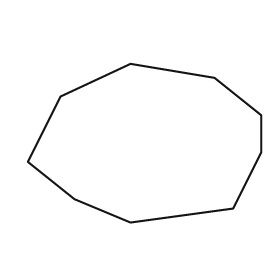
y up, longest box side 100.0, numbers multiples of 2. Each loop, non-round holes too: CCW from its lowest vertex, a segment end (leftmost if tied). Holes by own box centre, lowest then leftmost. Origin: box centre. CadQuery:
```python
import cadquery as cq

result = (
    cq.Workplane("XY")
    .moveTo(-6.0, -34.0)
    .lineTo(38.0, -28.0)
    .lineTo(50.0, -4.0)
    .lineTo(50.0, 12.0)
    .lineTo(30.0, 28.0)
    .lineTo(-6.0, 34.0)
    .lineTo(-36.0, 20.0)
    .lineTo(-50.0, -8.0)
    .lineTo(-30.0, -24.0)
    .close()
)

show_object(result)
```